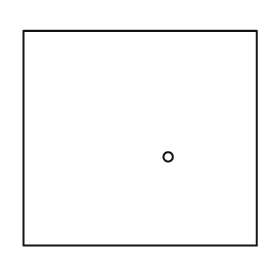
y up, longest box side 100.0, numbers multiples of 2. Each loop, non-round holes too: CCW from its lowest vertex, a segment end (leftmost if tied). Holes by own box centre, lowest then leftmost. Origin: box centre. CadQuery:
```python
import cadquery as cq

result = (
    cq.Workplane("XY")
    .moveTo(-50.0, -46.0)
    .lineTo(50.0, -46.0)
    .lineTo(50.0, 46.0)
    .lineTo(-50.0, 46.0)
    .close()
    .moveTo(12.0, -8.0)
    .circle(2.0)
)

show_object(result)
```